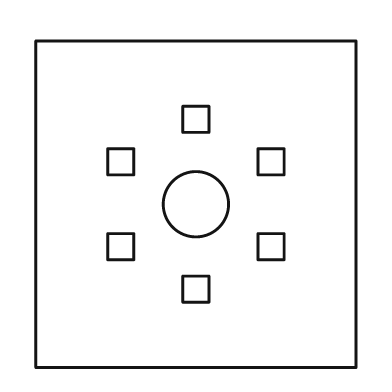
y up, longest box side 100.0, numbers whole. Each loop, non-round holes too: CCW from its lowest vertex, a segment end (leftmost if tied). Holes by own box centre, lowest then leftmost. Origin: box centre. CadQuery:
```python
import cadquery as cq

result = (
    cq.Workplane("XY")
    .moveTo(-49.0, -50.0)
    .lineTo(49.0, -50.0)
    .lineTo(49.0, 50.0)
    .lineTo(-49.0, 50.0)
    .close()
    .moveTo(-4.0, -30.0)
    .lineTo(4.0, -30.0)
    .lineTo(4.0, -22.0)
    .lineTo(-4.0, -22.0)
    .close()
    .moveTo(-27.0, -17.0)
    .lineTo(-19.0, -17.0)
    .lineTo(-19.0, -9.0)
    .lineTo(-27.0, -9.0)
    .close()
    .moveTo(19.0, -17.0)
    .lineTo(27.0, -17.0)
    .lineTo(27.0, -9.0)
    .lineTo(19.0, -9.0)
    .close()
    .moveTo(0.0, 0.0)
    .circle(10.0)
    .moveTo(-27.0, 9.0)
    .lineTo(-19.0, 9.0)
    .lineTo(-19.0, 17.0)
    .lineTo(-27.0, 17.0)
    .close()
    .moveTo(19.0, 9.0)
    .lineTo(27.0, 9.0)
    .lineTo(27.0, 17.0)
    .lineTo(19.0, 17.0)
    .close()
    .moveTo(-4.0, 22.0)
    .lineTo(4.0, 22.0)
    .lineTo(4.0, 30.0)
    .lineTo(-4.0, 30.0)
    .close()
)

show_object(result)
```